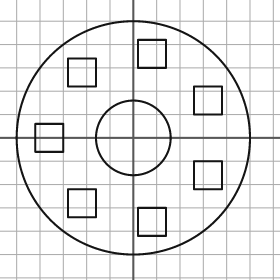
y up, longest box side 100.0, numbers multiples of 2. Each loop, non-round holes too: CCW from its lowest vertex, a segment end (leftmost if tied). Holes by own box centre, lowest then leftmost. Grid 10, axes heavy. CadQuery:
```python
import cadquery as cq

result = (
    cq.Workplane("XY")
    .moveTo(0.0, 0.0)
    .circle(50.0)
    .moveTo(2.0, -42.0)
    .lineTo(14.0, -42.0)
    .lineTo(14.0, -30.0)
    .lineTo(2.0, -30.0)
    .close()
    .moveTo(-28.0, -34.0)
    .lineTo(-16.0, -34.0)
    .lineTo(-16.0, -22.0)
    .lineTo(-28.0, -22.0)
    .close()
    .moveTo(26.0, -22.0)
    .lineTo(38.0, -22.0)
    .lineTo(38.0, -10.0)
    .lineTo(26.0, -10.0)
    .close()
    .moveTo(-42.0, -6.0)
    .lineTo(-30.0, -6.0)
    .lineTo(-30.0, 6.0)
    .lineTo(-42.0, 6.0)
    .close()
    .moveTo(0.0, 0.0)
    .circle(16.0)
    .moveTo(26.0, 10.0)
    .lineTo(38.0, 10.0)
    .lineTo(38.0, 22.0)
    .lineTo(26.0, 22.0)
    .close()
    .moveTo(-28.0, 22.0)
    .lineTo(-16.0, 22.0)
    .lineTo(-16.0, 34.0)
    .lineTo(-28.0, 34.0)
    .close()
    .moveTo(2.0, 30.0)
    .lineTo(14.0, 30.0)
    .lineTo(14.0, 42.0)
    .lineTo(2.0, 42.0)
    .close()
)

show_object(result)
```